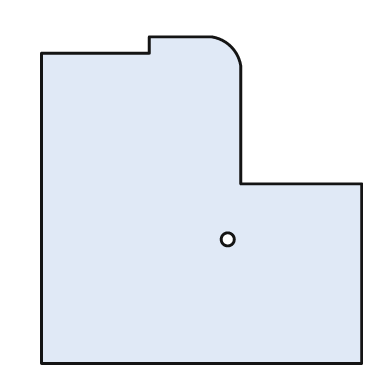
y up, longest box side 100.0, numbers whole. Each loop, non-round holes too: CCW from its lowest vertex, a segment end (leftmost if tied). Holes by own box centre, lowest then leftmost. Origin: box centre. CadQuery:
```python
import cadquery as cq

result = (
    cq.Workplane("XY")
    .moveTo(-49.0, -50.0)
    .lineTo(49.0, -50.0)
    .lineTo(49.0, 5.0)
    .lineTo(12.0, 5.0)
    .lineTo(12.0, 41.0)
    .threePointArc((9.0, 47.0), (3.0, 50.0))
    .lineTo(-16.0, 50.0)
    .lineTo(-16.0, 45.0)
    .lineTo(-49.0, 45.0)
    .close()
    .moveTo(8.0, -12.0)
    .circle(2.0)
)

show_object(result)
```